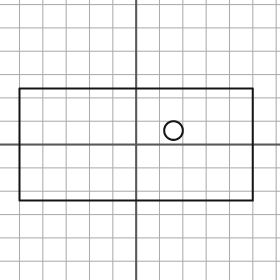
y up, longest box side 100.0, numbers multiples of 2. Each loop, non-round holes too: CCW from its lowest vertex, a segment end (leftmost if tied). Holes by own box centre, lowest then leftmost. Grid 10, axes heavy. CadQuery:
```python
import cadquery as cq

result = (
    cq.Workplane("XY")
    .moveTo(-50.0, -24.0)
    .lineTo(50.0, -24.0)
    .lineTo(50.0, 24.0)
    .lineTo(-50.0, 24.0)
    .close()
    .moveTo(16.0, 6.0)
    .circle(4.0)
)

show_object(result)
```